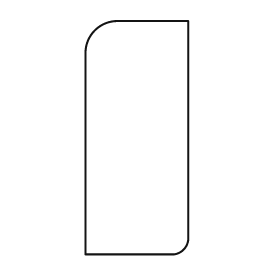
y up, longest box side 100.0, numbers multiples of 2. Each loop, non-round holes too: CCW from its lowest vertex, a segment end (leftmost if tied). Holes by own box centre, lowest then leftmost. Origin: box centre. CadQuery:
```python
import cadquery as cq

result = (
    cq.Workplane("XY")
    .moveTo(-22.0, -50.0)
    .lineTo(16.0, -50.0)
    .threePointArc((20.0, -48.0), (22.0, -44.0))
    .lineTo(22.0, 50.0)
    .lineTo(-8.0, 50.0)
    .threePointArc((-18.0, 46.0), (-22.0, 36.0))
    .close()
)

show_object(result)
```